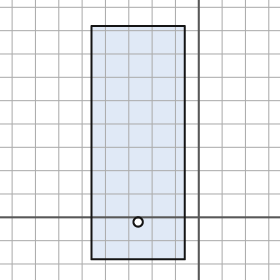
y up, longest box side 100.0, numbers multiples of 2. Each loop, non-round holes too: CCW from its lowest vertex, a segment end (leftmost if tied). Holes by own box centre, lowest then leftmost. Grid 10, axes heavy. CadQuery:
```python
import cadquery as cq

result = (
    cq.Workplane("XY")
    .moveTo(-46.0, -18.0)
    .lineTo(-6.0, -18.0)
    .lineTo(-6.0, 82.0)
    .lineTo(-46.0, 82.0)
    .close()
    .moveTo(-26.0, -2.0)
    .circle(2.0)
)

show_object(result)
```